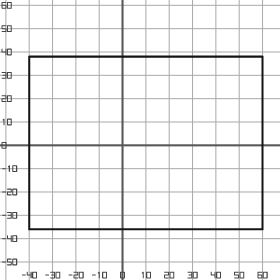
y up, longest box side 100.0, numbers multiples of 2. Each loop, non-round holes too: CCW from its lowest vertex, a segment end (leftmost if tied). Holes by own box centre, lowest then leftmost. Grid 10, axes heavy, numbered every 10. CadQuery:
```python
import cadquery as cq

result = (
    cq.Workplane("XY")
    .moveTo(-40.0, -36.0)
    .lineTo(60.0, -36.0)
    .lineTo(60.0, 38.0)
    .lineTo(-40.0, 38.0)
    .close()
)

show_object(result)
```